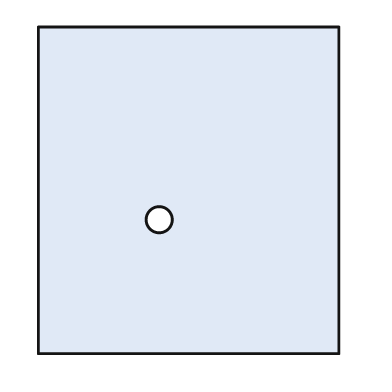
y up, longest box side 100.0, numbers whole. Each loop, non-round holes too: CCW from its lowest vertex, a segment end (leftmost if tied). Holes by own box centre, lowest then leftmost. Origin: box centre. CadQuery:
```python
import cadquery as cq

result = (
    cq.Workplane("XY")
    .moveTo(-46.0, -50.0)
    .lineTo(46.0, -50.0)
    .lineTo(46.0, 50.0)
    .lineTo(-46.0, 50.0)
    .close()
    .moveTo(-9.0, -9.0)
    .circle(4.0)
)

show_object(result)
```